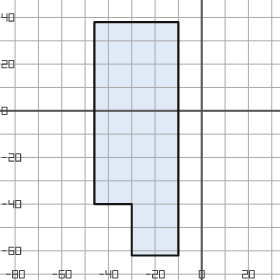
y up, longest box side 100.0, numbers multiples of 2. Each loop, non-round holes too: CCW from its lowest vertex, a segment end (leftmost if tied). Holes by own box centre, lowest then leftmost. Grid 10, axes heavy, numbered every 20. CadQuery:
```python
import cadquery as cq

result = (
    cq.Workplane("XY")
    .moveTo(-30.0, -62.0)
    .lineTo(-10.0, -62.0)
    .lineTo(-10.0, 38.0)
    .lineTo(-46.0, 38.0)
    .lineTo(-46.0, -40.0)
    .lineTo(-30.0, -40.0)
    .close()
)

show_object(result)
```